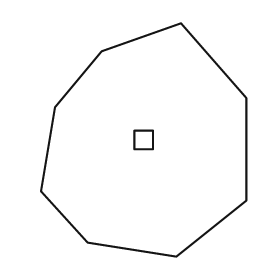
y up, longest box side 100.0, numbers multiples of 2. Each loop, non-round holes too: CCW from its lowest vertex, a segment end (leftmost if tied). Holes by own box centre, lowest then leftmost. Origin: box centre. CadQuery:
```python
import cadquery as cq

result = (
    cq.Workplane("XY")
    .moveTo(14.0, -50.0)
    .lineTo(44.0, -26.0)
    .lineTo(44.0, 18.0)
    .lineTo(16.0, 50.0)
    .lineTo(-18.0, 38.0)
    .lineTo(-38.0, 14.0)
    .lineTo(-44.0, -22.0)
    .lineTo(-24.0, -44.0)
    .close()
    .moveTo(-4.0, -4.0)
    .lineTo(4.0, -4.0)
    .lineTo(4.0, 4.0)
    .lineTo(-4.0, 4.0)
    .close()
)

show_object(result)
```